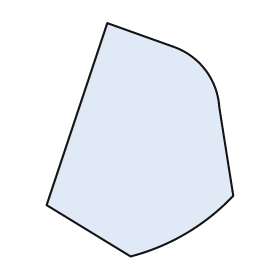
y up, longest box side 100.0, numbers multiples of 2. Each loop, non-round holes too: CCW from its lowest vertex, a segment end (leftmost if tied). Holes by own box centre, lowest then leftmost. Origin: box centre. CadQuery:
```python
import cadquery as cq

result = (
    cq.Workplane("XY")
    .moveTo(-4.0, -50.0)
    .threePointArc((20.0, -40.0), (40.0, -24.0))
    .lineTo(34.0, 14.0)
    .threePointArc((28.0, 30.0), (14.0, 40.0))
    .lineTo(-14.0, 50.0)
    .lineTo(-40.0, -28.0)
    .close()
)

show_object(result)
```